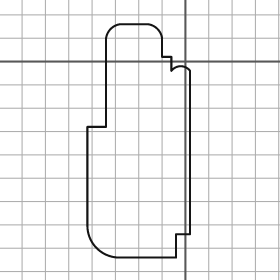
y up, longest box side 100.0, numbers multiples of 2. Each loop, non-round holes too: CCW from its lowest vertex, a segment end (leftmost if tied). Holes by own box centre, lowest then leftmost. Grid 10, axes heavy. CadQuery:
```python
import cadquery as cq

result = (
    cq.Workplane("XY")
    .moveTo(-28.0, -84.0)
    .lineTo(-4.0, -84.0)
    .lineTo(-4.0, -74.0)
    .lineTo(2.0, -74.0)
    .lineTo(2.0, -4.0)
    .threePointArc((-2.0, -2.0), (-6.0, -4.0))
    .lineTo(-6.0, 2.0)
    .lineTo(-10.0, 2.0)
    .lineTo(-10.0, 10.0)
    .threePointArc((-12.0, 14.0), (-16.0, 16.0))
    .lineTo(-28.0, 16.0)
    .threePointArc((-32.0, 14.0), (-34.0, 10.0))
    .lineTo(-34.0, -28.0)
    .lineTo(-42.0, -28.0)
    .lineTo(-42.0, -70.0)
    .threePointArc((-38.0, -80.0), (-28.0, -84.0))
    .close()
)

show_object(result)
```